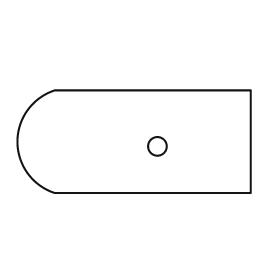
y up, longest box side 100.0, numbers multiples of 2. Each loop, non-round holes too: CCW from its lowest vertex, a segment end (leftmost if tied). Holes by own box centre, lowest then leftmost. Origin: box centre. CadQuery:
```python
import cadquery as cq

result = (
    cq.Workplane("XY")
    .moveTo(-34.0, -22.0)
    .lineTo(50.0, -22.0)
    .lineTo(50.0, 22.0)
    .lineTo(-34.0, 22.0)
    .threePointArc((-50.0, 0.0), (-34.0, -22.0))
    .close()
    .moveTo(10.0, -2.0)
    .circle(4.0)
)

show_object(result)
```